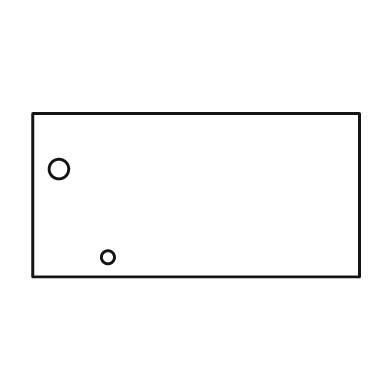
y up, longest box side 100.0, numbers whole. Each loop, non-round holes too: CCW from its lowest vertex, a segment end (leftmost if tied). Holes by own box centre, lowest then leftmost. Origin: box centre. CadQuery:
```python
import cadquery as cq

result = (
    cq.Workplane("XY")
    .moveTo(-50.0, -25.0)
    .lineTo(50.0, -25.0)
    .lineTo(50.0, 25.0)
    .lineTo(-50.0, 25.0)
    .close()
    .moveTo(-27.0, -19.0)
    .circle(2.0)
    .moveTo(-42.0, 8.0)
    .circle(3.0)
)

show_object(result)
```